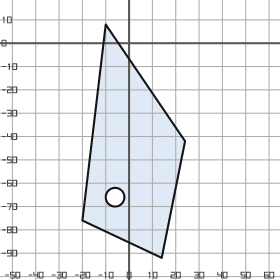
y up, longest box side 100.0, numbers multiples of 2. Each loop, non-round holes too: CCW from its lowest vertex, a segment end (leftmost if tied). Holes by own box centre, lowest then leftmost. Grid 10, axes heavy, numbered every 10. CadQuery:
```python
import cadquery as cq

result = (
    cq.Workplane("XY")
    .moveTo(14.0, -92.0)
    .lineTo(24.0, -42.0)
    .lineTo(-10.0, 8.0)
    .lineTo(-20.0, -76.0)
    .close()
    .moveTo(-6.0, -66.0)
    .circle(4.0)
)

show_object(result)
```